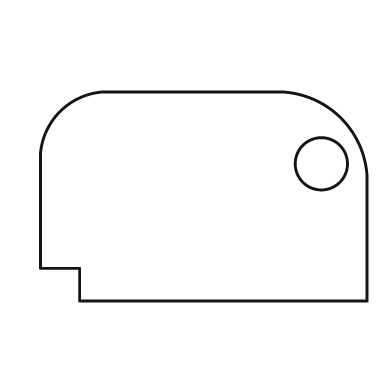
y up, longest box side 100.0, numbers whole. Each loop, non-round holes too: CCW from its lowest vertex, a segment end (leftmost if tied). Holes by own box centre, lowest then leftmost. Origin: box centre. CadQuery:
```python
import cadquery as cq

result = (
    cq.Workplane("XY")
    .moveTo(-38.0, -32.0)
    .lineTo(50.0, -32.0)
    .lineTo(50.0, 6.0)
    .threePointArc((42.0, 24.0), (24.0, 32.0))
    .lineTo(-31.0, 32.0)
    .threePointArc((-44.0, 26.0), (-50.0, 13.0))
    .lineTo(-50.0, -22.0)
    .lineTo(-38.0, -22.0)
    .close()
    .moveTo(36.0, 10.0)
    .circle(8.0)
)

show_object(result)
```